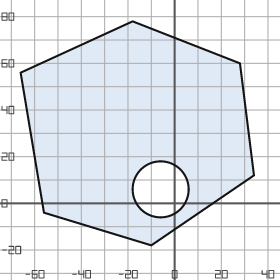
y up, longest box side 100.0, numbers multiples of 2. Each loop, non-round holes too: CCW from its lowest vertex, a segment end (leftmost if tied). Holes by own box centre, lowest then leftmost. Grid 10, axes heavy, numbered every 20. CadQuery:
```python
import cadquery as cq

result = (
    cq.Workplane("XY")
    .moveTo(-10.0, -18.0)
    .lineTo(34.0, 12.0)
    .lineTo(28.0, 60.0)
    .lineTo(-18.0, 78.0)
    .lineTo(-66.0, 56.0)
    .lineTo(-56.0, -4.0)
    .close()
    .moveTo(-6.0, 6.0)
    .circle(12.0)
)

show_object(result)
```